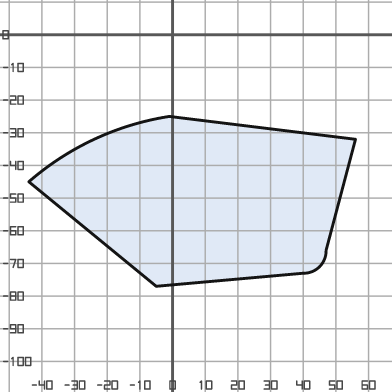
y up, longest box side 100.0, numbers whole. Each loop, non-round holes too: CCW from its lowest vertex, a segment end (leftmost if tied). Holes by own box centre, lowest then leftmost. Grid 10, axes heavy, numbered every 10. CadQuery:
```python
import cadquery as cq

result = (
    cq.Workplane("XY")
    .moveTo(-5.0, -77.0)
    .lineTo(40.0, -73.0)
    .threePointArc((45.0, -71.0), (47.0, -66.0))
    .lineTo(56.0, -32.0)
    .lineTo(-1.0, -25.0)
    .threePointArc((-24.0, -32.0), (-44.0, -45.0))
    .close()
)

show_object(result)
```